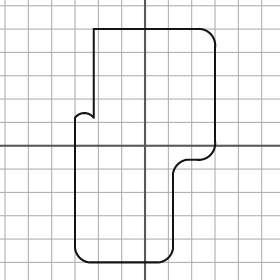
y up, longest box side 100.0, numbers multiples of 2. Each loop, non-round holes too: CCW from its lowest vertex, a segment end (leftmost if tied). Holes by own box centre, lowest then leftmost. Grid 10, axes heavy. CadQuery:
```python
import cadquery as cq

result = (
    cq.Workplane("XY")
    .moveTo(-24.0, -50.0)
    .lineTo(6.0, -50.0)
    .threePointArc((10.0, -48.0), (12.0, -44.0))
    .lineTo(12.0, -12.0)
    .threePointArc((14.0, -8.0), (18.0, -6.0))
    .lineTo(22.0, -6.0)
    .threePointArc((28.0, -4.0), (30.0, 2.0))
    .lineTo(30.0, 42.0)
    .threePointArc((28.0, 48.0), (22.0, 50.0))
    .lineTo(-22.0, 50.0)
    .lineTo(-22.0, 12.0)
    .threePointArc((-26.0, 14.0), (-30.0, 12.0))
    .lineTo(-30.0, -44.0)
    .threePointArc((-28.0, -48.0), (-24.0, -50.0))
    .close()
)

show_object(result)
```